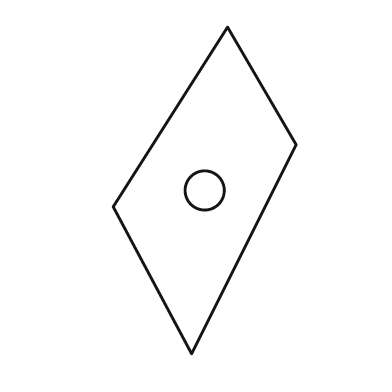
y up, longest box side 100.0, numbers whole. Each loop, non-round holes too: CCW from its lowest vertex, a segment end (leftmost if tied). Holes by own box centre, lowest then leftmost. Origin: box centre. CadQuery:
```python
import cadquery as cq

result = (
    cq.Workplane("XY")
    .moveTo(-4.0, -50.0)
    .lineTo(28.0, 14.0)
    .lineTo(7.0, 50.0)
    .lineTo(-28.0, -5.0)
    .close()
    .moveTo(0.0, 0.0)
    .circle(6.0)
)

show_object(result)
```